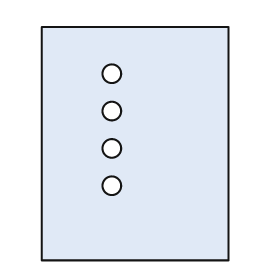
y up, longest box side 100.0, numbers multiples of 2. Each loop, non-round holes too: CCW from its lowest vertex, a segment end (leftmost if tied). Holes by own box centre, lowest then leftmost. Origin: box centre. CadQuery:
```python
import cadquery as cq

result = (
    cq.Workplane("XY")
    .moveTo(-40.0, -50.0)
    .lineTo(40.0, -50.0)
    .lineTo(40.0, 50.0)
    .lineTo(-40.0, 50.0)
    .close()
    .moveTo(-10.0, -18.0)
    .circle(4.0)
    .moveTo(-10.0, -2.0)
    .circle(4.0)
    .moveTo(-10.0, 14.0)
    .circle(4.0)
    .moveTo(-10.0, 30.0)
    .circle(4.0)
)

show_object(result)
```